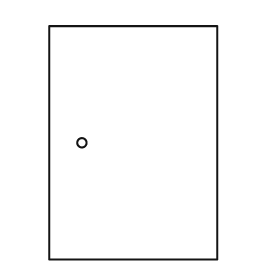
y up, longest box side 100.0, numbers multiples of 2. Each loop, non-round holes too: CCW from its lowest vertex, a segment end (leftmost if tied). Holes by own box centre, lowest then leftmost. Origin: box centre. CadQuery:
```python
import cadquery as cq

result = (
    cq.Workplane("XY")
    .moveTo(-36.0, -50.0)
    .lineTo(36.0, -50.0)
    .lineTo(36.0, 50.0)
    .lineTo(-36.0, 50.0)
    .close()
    .moveTo(-22.0, 0.0)
    .circle(2.0)
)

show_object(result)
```